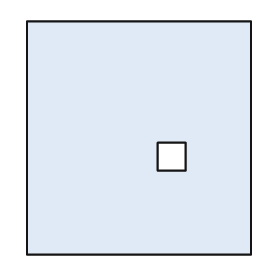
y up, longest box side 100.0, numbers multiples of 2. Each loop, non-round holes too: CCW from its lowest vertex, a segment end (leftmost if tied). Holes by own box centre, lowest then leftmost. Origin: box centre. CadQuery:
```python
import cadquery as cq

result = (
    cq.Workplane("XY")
    .moveTo(-48.0, -50.0)
    .lineTo(48.0, -50.0)
    .lineTo(48.0, 50.0)
    .lineTo(-48.0, 50.0)
    .close()
    .moveTo(8.0, -14.0)
    .lineTo(20.0, -14.0)
    .lineTo(20.0, -2.0)
    .lineTo(8.0, -2.0)
    .close()
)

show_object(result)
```